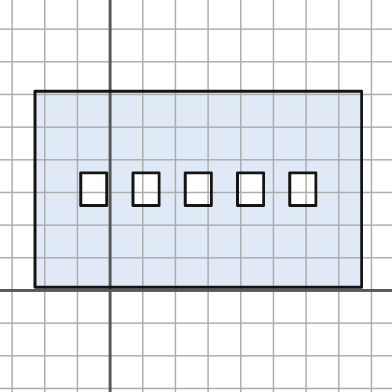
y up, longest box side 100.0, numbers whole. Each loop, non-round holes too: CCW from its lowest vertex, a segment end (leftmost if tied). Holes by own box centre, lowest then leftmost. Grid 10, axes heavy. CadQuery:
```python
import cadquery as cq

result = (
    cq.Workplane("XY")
    .moveTo(-23.0, 1.0)
    .lineTo(77.0, 1.0)
    .lineTo(77.0, 61.0)
    .lineTo(-23.0, 61.0)
    .close()
    .moveTo(-9.0, 26.0)
    .lineTo(-1.0, 26.0)
    .lineTo(-1.0, 36.0)
    .lineTo(-9.0, 36.0)
    .close()
    .moveTo(7.0, 26.0)
    .lineTo(15.0, 26.0)
    .lineTo(15.0, 36.0)
    .lineTo(7.0, 36.0)
    .close()
    .moveTo(23.0, 26.0)
    .lineTo(31.0, 26.0)
    .lineTo(31.0, 36.0)
    .lineTo(23.0, 36.0)
    .close()
    .moveTo(39.0, 26.0)
    .lineTo(47.0, 26.0)
    .lineTo(47.0, 36.0)
    .lineTo(39.0, 36.0)
    .close()
    .moveTo(55.0, 26.0)
    .lineTo(63.0, 26.0)
    .lineTo(63.0, 36.0)
    .lineTo(55.0, 36.0)
    .close()
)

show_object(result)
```